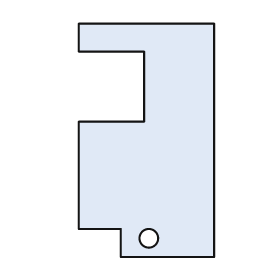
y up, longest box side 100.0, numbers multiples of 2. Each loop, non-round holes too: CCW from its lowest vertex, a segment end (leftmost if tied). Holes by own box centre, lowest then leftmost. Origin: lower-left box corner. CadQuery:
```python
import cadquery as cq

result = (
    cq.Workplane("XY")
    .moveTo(18.0, 0.0)
    .lineTo(58.0, 0.0)
    .lineTo(58.0, 100.0)
    .lineTo(0.0, 100.0)
    .lineTo(0.0, 88.0)
    .lineTo(28.0, 88.0)
    .lineTo(28.0, 58.0)
    .lineTo(0.0, 58.0)
    .lineTo(0.0, 12.0)
    .lineTo(18.0, 12.0)
    .close()
    .moveTo(30.0, 8.0)
    .circle(4.0)
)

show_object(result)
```